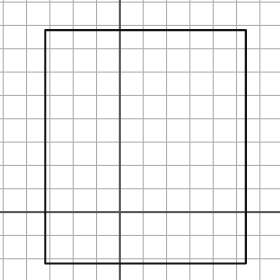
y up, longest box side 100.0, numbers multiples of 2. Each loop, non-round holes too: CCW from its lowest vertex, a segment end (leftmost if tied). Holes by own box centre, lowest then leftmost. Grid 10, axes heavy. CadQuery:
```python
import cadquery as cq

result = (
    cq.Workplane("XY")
    .moveTo(-32.0, -22.0)
    .lineTo(54.0, -22.0)
    .lineTo(54.0, 78.0)
    .lineTo(-32.0, 78.0)
    .close()
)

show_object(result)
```